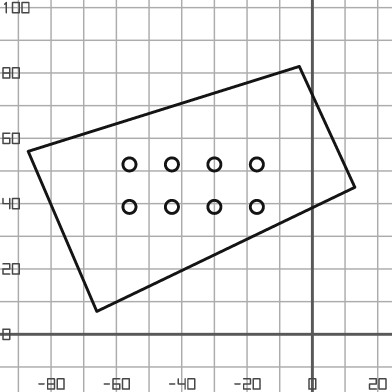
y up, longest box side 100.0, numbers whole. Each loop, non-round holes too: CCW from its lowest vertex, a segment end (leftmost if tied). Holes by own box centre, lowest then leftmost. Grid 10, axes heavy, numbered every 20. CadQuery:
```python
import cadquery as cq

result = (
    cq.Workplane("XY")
    .moveTo(-66.0, 7.0)
    .lineTo(13.0, 45.0)
    .lineTo(-4.0, 82.0)
    .lineTo(-87.0, 56.0)
    .close()
    .moveTo(-56.0, 39.0)
    .circle(2.0)
    .moveTo(-43.0, 39.0)
    .circle(2.0)
    .moveTo(-30.0, 39.0)
    .circle(2.0)
    .moveTo(-17.0, 39.0)
    .circle(2.0)
    .moveTo(-56.0, 52.0)
    .circle(2.0)
    .moveTo(-43.0, 52.0)
    .circle(2.0)
    .moveTo(-30.0, 52.0)
    .circle(2.0)
    .moveTo(-17.0, 52.0)
    .circle(2.0)
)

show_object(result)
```